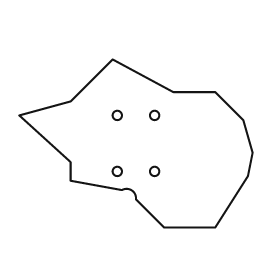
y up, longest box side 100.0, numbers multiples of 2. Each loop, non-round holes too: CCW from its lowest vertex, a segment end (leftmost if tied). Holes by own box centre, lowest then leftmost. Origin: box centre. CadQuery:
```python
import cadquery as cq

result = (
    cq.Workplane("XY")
    .moveTo(12.0, -36.0)
    .lineTo(34.0, -36.0)
    .lineTo(48.0, -14.0)
    .lineTo(50.0, -4.0)
    .lineTo(46.0, 10.0)
    .lineTo(34.0, 22.0)
    .lineTo(16.0, 22.0)
    .lineTo(-10.0, 36.0)
    .lineTo(-28.0, 18.0)
    .lineTo(-50.0, 12.0)
    .lineTo(-28.0, -8.0)
    .lineTo(-28.0, -16.0)
    .lineTo(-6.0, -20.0)
    .threePointArc((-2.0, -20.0), (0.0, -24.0))
    .close()
    .moveTo(-8.0, -12.0)
    .circle(2.0)
    .moveTo(8.0, -12.0)
    .circle(2.0)
    .moveTo(-8.0, 12.0)
    .circle(2.0)
    .moveTo(8.0, 12.0)
    .circle(2.0)
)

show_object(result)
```